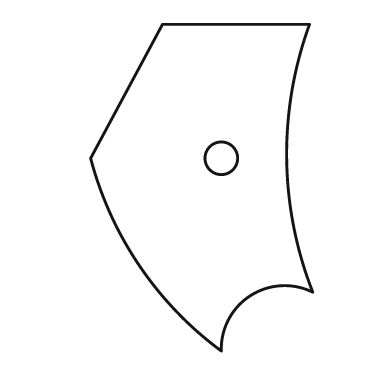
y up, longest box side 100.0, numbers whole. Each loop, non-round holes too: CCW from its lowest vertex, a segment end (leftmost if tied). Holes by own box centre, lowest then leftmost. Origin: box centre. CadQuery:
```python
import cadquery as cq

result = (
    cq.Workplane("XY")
    .moveTo(6.0, -50.0)
    .threePointArc((15.0, -33.0), (34.0, -32.0))
    .threePointArc((26.0, 9.0), (33.0, 50.0))
    .lineTo(-12.0, 50.0)
    .lineTo(-34.0, 9.0)
    .threePointArc((-19.0, -24.0), (6.0, -50.0))
    .close()
    .moveTo(6.0, 9.0)
    .circle(5.0)
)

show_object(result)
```